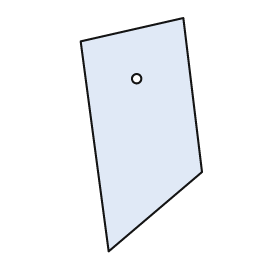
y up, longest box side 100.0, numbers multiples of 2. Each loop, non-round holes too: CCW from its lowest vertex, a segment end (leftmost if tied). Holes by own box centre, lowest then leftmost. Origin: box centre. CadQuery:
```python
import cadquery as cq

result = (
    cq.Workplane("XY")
    .moveTo(-14.0, -50.0)
    .lineTo(26.0, -16.0)
    .lineTo(18.0, 50.0)
    .lineTo(-26.0, 40.0)
    .close()
    .moveTo(-2.0, 24.0)
    .circle(2.0)
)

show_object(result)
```